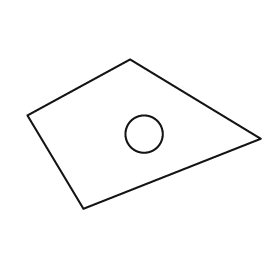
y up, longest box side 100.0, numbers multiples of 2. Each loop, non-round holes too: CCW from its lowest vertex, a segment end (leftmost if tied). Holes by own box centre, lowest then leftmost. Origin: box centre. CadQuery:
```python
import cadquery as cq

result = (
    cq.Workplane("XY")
    .moveTo(-26.0, -32.0)
    .lineTo(50.0, -2.0)
    .lineTo(-6.0, 32.0)
    .lineTo(-50.0, 8.0)
    .close()
    .moveTo(0.0, 0.0)
    .circle(8.0)
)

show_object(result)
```